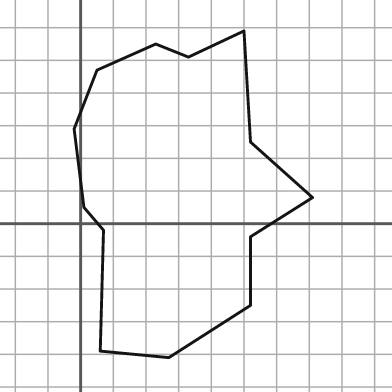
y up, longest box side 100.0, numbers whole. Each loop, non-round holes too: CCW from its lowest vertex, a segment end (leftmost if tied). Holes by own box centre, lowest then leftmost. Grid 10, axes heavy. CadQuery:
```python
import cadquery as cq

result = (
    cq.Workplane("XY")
    .moveTo(27.0, -41.0)
    .lineTo(52.0, -25.0)
    .lineTo(52.0, -4.0)
    .lineTo(71.0, 8.0)
    .lineTo(52.0, 25.0)
    .lineTo(50.0, 59.0)
    .lineTo(33.0, 51.0)
    .lineTo(23.0, 55.0)
    .lineTo(5.0, 47.0)
    .lineTo(-2.0, 29.0)
    .lineTo(1.0, 5.0)
    .lineTo(7.0, -2.0)
    .lineTo(6.0, -39.0)
    .close()
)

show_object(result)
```